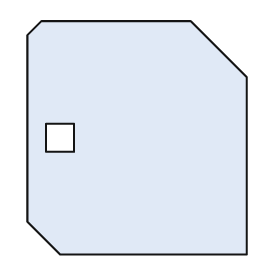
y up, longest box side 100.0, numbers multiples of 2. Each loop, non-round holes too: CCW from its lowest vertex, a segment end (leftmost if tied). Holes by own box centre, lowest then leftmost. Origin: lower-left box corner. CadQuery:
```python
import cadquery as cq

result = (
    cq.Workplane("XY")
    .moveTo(14.0, 0.0)
    .lineTo(94.0, 0.0)
    .lineTo(94.0, 76.0)
    .lineTo(70.0, 100.0)
    .lineTo(6.0, 100.0)
    .lineTo(0.0, 94.0)
    .lineTo(0.0, 14.0)
    .close()
    .moveTo(8.0, 44.0)
    .lineTo(20.0, 44.0)
    .lineTo(20.0, 56.0)
    .lineTo(8.0, 56.0)
    .close()
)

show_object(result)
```